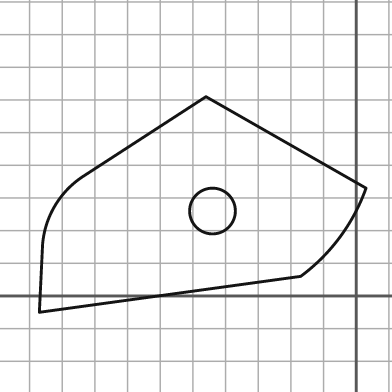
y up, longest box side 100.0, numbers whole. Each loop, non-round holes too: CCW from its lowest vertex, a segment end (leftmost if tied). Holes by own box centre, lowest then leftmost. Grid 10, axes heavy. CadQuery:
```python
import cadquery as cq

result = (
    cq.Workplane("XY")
    .moveTo(-97.0, -5.0)
    .lineTo(-17.0, 6.0)
    .threePointArc((-5.0, 18.0), (3.0, 33.0))
    .lineTo(-46.0, 61.0)
    .lineTo(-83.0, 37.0)
    .threePointArc((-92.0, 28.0), (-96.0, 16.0))
    .close()
    .moveTo(-44.0, 26.0)
    .circle(7.0)
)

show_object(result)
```